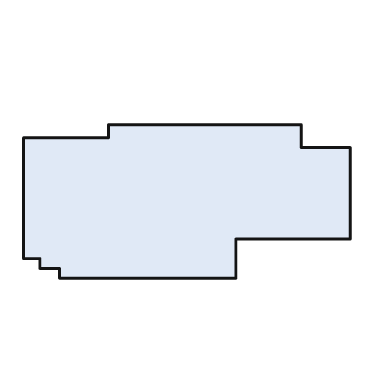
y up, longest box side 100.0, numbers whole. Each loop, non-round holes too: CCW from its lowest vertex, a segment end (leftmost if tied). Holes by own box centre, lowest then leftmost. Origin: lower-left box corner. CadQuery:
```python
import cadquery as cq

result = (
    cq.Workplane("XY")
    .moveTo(11.0, 0.0)
    .lineTo(65.0, 0.0)
    .lineTo(65.0, 12.0)
    .lineTo(100.0, 12.0)
    .lineTo(100.0, 40.0)
    .lineTo(85.0, 40.0)
    .lineTo(85.0, 47.0)
    .lineTo(26.0, 47.0)
    .lineTo(26.0, 43.0)
    .lineTo(0.0, 43.0)
    .lineTo(0.0, 6.0)
    .lineTo(5.0, 6.0)
    .lineTo(5.0, 3.0)
    .lineTo(11.0, 3.0)
    .close()
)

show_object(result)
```